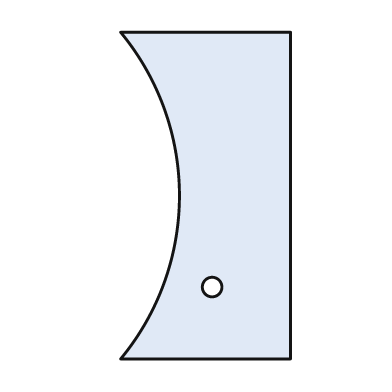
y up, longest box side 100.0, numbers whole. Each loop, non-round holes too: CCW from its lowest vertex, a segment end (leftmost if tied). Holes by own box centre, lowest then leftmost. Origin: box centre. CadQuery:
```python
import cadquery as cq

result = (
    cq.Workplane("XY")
    .moveTo(-26.0, -50.0)
    .lineTo(26.0, -50.0)
    .lineTo(26.0, 50.0)
    .lineTo(-26.0, 50.0)
    .threePointArc((-8.0, 0.0), (-26.0, -50.0))
    .close()
    .moveTo(2.0, -28.0)
    .circle(3.0)
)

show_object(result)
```